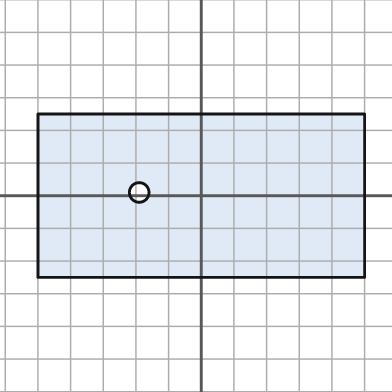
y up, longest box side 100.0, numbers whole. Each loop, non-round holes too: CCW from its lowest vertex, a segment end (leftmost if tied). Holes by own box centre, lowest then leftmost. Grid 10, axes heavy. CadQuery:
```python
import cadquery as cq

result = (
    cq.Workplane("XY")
    .moveTo(-50.0, -25.0)
    .lineTo(50.0, -25.0)
    .lineTo(50.0, 25.0)
    .lineTo(-50.0, 25.0)
    .close()
    .moveTo(-19.0, 1.0)
    .circle(3.0)
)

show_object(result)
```